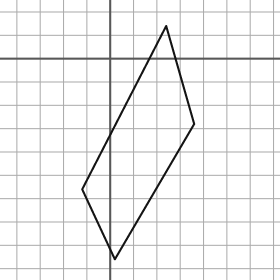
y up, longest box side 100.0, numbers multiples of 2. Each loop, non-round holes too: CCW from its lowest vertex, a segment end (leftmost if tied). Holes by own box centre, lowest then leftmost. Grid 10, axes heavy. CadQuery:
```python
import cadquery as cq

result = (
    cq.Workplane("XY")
    .moveTo(2.0, -86.0)
    .lineTo(36.0, -28.0)
    .lineTo(24.0, 14.0)
    .lineTo(-12.0, -56.0)
    .close()
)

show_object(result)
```